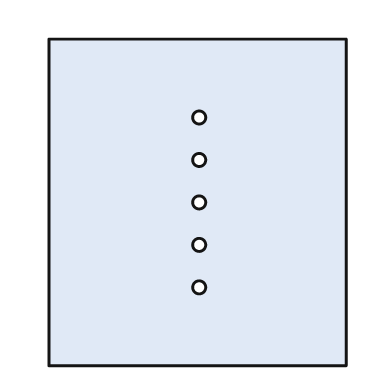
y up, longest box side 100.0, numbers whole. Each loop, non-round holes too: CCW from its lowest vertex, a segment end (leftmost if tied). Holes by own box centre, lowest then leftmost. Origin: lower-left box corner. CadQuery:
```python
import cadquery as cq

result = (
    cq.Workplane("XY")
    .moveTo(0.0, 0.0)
    .lineTo(91.0, 0.0)
    .lineTo(91.0, 100.0)
    .lineTo(0.0, 100.0)
    .close()
    .moveTo(46.0, 24.0)
    .circle(2.0)
    .moveTo(46.0, 37.0)
    .circle(2.0)
    .moveTo(46.0, 50.0)
    .circle(2.0)
    .moveTo(46.0, 63.0)
    .circle(2.0)
    .moveTo(46.0, 76.0)
    .circle(2.0)
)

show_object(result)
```